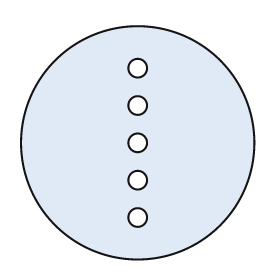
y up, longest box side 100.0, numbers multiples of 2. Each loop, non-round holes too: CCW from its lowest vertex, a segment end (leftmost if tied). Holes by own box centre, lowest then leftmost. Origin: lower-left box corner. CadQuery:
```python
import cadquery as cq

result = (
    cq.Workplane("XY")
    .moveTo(50.0, 50.0)
    .circle(50.0)
    .moveTo(50.0, 18.0)
    .circle(4.0)
    .moveTo(50.0, 34.0)
    .circle(4.0)
    .moveTo(50.0, 50.0)
    .circle(4.0)
    .moveTo(50.0, 66.0)
    .circle(4.0)
    .moveTo(50.0, 82.0)
    .circle(4.0)
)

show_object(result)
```